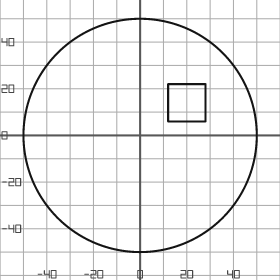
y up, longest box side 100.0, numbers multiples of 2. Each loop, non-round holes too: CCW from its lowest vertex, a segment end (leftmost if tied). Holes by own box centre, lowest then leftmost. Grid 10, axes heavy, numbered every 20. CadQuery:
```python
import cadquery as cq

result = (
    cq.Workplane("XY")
    .moveTo(0.0, 0.0)
    .circle(50.0)
    .moveTo(12.0, 6.0)
    .lineTo(28.0, 6.0)
    .lineTo(28.0, 22.0)
    .lineTo(12.0, 22.0)
    .close()
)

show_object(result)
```